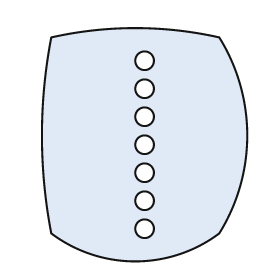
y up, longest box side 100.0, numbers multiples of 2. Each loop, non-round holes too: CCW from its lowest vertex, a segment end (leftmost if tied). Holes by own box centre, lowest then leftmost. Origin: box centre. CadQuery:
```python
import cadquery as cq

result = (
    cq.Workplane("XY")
    .moveTo(-40.0, -38.0)
    .threePointArc((-4.0, -50.0), (32.0, -38.0))
    .threePointArc((44.0, 4.0), (32.0, 46.0))
    .threePointArc((-4.0, 50.0), (-40.0, 46.0))
    .threePointArc((-44.0, 4.0), (-40.0, -38.0))
    .close()
    .moveTo(0.0, -36.0)
    .circle(4.0)
    .moveTo(0.0, -24.0)
    .circle(4.0)
    .moveTo(0.0, -12.0)
    .circle(4.0)
    .moveTo(0.0, 0.0)
    .circle(4.0)
    .moveTo(0.0, 12.0)
    .circle(4.0)
    .moveTo(0.0, 24.0)
    .circle(4.0)
    .moveTo(0.0, 36.0)
    .circle(4.0)
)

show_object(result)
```